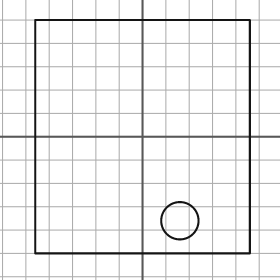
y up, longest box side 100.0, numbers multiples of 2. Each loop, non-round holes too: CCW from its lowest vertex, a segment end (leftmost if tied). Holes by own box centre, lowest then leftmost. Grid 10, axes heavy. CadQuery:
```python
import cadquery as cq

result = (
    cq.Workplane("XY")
    .moveTo(-46.0, -50.0)
    .lineTo(46.0, -50.0)
    .lineTo(46.0, 50.0)
    .lineTo(-46.0, 50.0)
    .close()
    .moveTo(16.0, -36.0)
    .circle(8.0)
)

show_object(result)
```